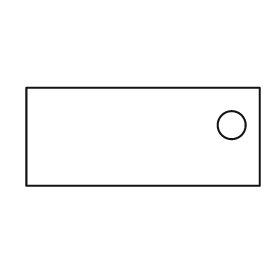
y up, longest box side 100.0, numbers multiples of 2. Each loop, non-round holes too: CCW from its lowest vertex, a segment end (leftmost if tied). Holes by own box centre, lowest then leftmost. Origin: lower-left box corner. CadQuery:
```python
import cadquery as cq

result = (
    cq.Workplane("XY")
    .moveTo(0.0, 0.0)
    .lineTo(100.0, 0.0)
    .lineTo(100.0, 42.0)
    .lineTo(0.0, 42.0)
    .close()
    .moveTo(88.0, 26.0)
    .circle(6.0)
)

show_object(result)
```